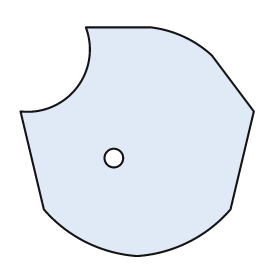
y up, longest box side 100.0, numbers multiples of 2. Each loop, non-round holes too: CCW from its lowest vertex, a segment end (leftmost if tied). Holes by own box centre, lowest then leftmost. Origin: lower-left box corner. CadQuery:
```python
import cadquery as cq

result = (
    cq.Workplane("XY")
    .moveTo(50.0, 0.0)
    .threePointArc((72.0, 6.0), (90.0, 20.0))
    .lineTo(100.0, 62.0)
    .lineTo(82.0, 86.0)
    .threePointArc((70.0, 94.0), (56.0, 98.0))
    .lineTo(28.0, 98.0)
    .threePointArc((24.0, 72.0), (0.0, 62.0))
    .lineTo(10.0, 20.0)
    .threePointArc((28.0, 6.0), (50.0, 0.0))
    .close()
    .moveTo(40.0, 42.0)
    .circle(4.0)
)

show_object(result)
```